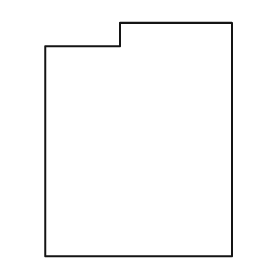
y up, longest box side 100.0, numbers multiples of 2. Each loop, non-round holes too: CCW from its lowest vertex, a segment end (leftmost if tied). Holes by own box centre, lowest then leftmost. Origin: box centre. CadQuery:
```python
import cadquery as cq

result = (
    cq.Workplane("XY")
    .moveTo(-40.0, -50.0)
    .lineTo(40.0, -50.0)
    .lineTo(40.0, 50.0)
    .lineTo(-8.0, 50.0)
    .lineTo(-8.0, 40.0)
    .lineTo(-40.0, 40.0)
    .close()
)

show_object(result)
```